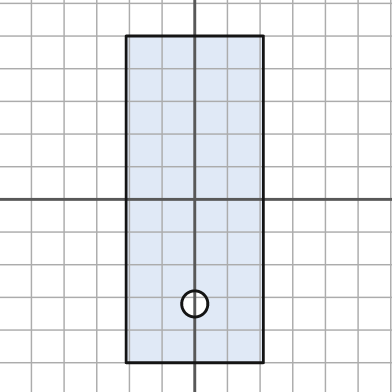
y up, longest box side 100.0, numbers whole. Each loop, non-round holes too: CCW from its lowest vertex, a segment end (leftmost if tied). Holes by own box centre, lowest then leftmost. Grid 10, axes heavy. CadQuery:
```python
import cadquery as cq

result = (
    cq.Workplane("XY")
    .moveTo(-21.0, -50.0)
    .lineTo(21.0, -50.0)
    .lineTo(21.0, 50.0)
    .lineTo(-21.0, 50.0)
    .close()
    .moveTo(0.0, -32.0)
    .circle(4.0)
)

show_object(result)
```